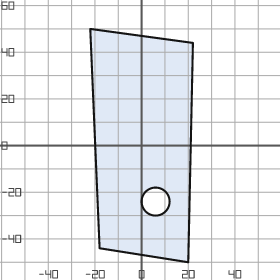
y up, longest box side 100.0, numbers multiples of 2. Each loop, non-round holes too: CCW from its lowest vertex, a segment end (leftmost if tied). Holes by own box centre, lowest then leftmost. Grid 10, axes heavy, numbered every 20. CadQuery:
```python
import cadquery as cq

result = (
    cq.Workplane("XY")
    .moveTo(20.0, -50.0)
    .lineTo(22.0, 44.0)
    .lineTo(-22.0, 50.0)
    .lineTo(-18.0, -44.0)
    .close()
    .moveTo(6.0, -24.0)
    .circle(6.0)
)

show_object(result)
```